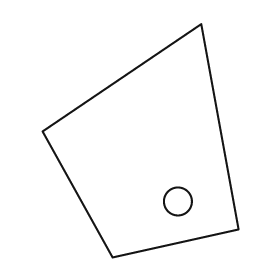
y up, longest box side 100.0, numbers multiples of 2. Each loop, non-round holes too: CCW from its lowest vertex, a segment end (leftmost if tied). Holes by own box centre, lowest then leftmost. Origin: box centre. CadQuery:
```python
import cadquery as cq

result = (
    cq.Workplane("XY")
    .moveTo(-12.0, -50.0)
    .lineTo(42.0, -38.0)
    .lineTo(26.0, 50.0)
    .lineTo(-42.0, 4.0)
    .close()
    .moveTo(16.0, -26.0)
    .circle(6.0)
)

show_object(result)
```